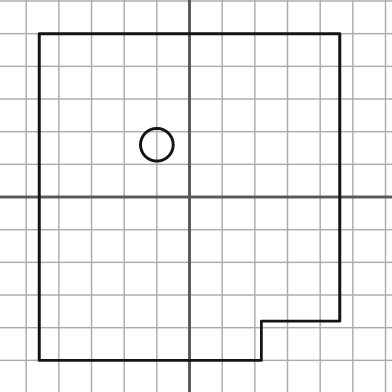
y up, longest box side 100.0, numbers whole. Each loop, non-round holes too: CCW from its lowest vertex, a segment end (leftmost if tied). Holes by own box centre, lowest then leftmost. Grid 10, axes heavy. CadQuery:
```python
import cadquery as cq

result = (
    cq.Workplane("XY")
    .moveTo(-46.0, -50.0)
    .lineTo(22.0, -50.0)
    .lineTo(22.0, -38.0)
    .lineTo(46.0, -38.0)
    .lineTo(46.0, 50.0)
    .lineTo(-46.0, 50.0)
    .close()
    .moveTo(-10.0, 16.0)
    .circle(5.0)
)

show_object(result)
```